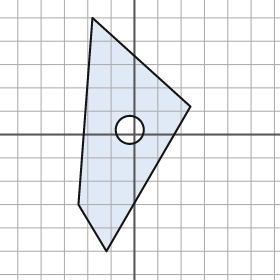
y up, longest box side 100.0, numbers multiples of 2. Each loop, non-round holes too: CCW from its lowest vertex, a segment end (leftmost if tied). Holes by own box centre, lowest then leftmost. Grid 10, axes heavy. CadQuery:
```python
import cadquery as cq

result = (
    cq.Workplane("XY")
    .moveTo(-12.0, -50.0)
    .lineTo(24.0, 12.0)
    .lineTo(-18.0, 50.0)
    .lineTo(-24.0, -30.0)
    .close()
    .moveTo(-2.0, 2.0)
    .circle(6.0)
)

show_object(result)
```